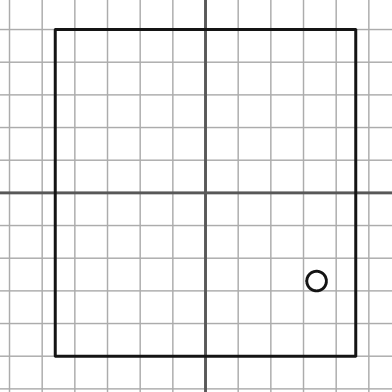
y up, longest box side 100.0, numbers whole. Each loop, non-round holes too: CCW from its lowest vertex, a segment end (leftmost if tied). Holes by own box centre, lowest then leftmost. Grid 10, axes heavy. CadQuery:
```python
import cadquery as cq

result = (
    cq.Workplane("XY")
    .moveTo(-46.0, -50.0)
    .lineTo(46.0, -50.0)
    .lineTo(46.0, 50.0)
    .lineTo(-46.0, 50.0)
    .close()
    .moveTo(34.0, -27.0)
    .circle(3.0)
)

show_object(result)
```